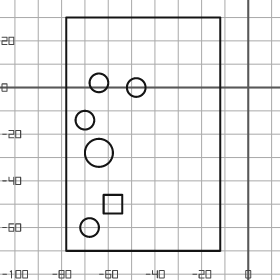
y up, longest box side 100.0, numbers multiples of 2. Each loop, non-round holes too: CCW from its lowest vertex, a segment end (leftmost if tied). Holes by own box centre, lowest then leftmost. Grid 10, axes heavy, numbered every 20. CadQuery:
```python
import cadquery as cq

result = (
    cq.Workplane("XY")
    .moveTo(-78.0, -70.0)
    .lineTo(-12.0, -70.0)
    .lineTo(-12.0, 30.0)
    .lineTo(-78.0, 30.0)
    .close()
    .moveTo(-68.0, -60.0)
    .circle(4.0)
    .moveTo(-62.0, -54.0)
    .lineTo(-54.0, -54.0)
    .lineTo(-54.0, -46.0)
    .lineTo(-62.0, -46.0)
    .close()
    .moveTo(-64.0, -28.0)
    .circle(6.0)
    .moveTo(-70.0, -14.0)
    .circle(4.0)
    .moveTo(-48.0, 0.0)
    .circle(4.0)
    .moveTo(-64.0, 2.0)
    .circle(4.0)
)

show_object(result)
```